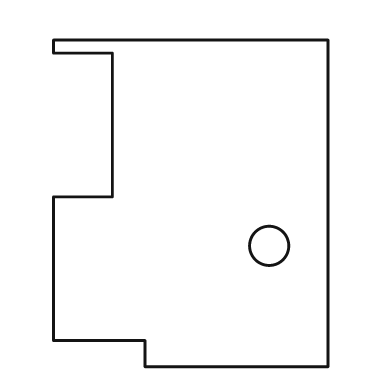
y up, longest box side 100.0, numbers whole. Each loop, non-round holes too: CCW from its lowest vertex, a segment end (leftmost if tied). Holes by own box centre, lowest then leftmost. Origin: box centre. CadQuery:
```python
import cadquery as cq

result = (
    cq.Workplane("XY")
    .moveTo(-14.0, -50.0)
    .lineTo(42.0, -50.0)
    .lineTo(42.0, 50.0)
    .lineTo(-42.0, 50.0)
    .lineTo(-42.0, 46.0)
    .lineTo(-24.0, 46.0)
    .lineTo(-24.0, 2.0)
    .lineTo(-42.0, 2.0)
    .lineTo(-42.0, -42.0)
    .lineTo(-14.0, -42.0)
    .close()
    .moveTo(24.0, -13.0)
    .circle(6.0)
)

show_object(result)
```